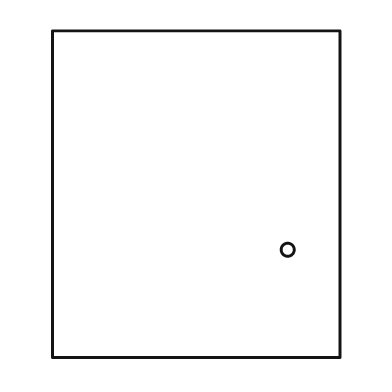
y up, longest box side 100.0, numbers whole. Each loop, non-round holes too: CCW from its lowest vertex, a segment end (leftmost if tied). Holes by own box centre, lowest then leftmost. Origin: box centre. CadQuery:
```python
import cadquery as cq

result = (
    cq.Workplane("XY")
    .moveTo(-44.0, -50.0)
    .lineTo(44.0, -50.0)
    .lineTo(44.0, 50.0)
    .lineTo(-44.0, 50.0)
    .close()
    .moveTo(28.0, -17.0)
    .circle(2.0)
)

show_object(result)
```